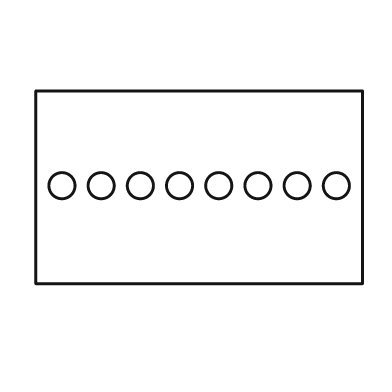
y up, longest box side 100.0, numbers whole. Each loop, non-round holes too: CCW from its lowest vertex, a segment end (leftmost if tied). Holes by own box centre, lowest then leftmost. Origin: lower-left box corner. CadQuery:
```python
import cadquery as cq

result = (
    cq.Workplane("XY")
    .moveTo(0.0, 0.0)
    .lineTo(100.0, 0.0)
    .lineTo(100.0, 59.0)
    .lineTo(0.0, 59.0)
    .close()
    .moveTo(8.0, 30.0)
    .circle(4.0)
    .moveTo(20.0, 30.0)
    .circle(4.0)
    .moveTo(32.0, 30.0)
    .circle(4.0)
    .moveTo(44.0, 30.0)
    .circle(4.0)
    .moveTo(56.0, 30.0)
    .circle(4.0)
    .moveTo(68.0, 30.0)
    .circle(4.0)
    .moveTo(80.0, 30.0)
    .circle(4.0)
    .moveTo(92.0, 30.0)
    .circle(4.0)
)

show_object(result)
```